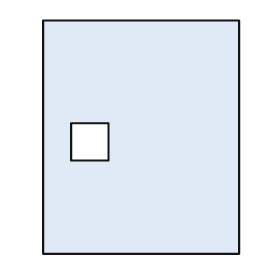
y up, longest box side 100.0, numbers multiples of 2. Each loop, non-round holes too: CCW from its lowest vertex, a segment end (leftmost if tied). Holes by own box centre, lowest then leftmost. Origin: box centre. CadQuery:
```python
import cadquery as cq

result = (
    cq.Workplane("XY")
    .moveTo(-42.0, -50.0)
    .lineTo(42.0, -50.0)
    .lineTo(42.0, 50.0)
    .lineTo(-42.0, 50.0)
    .close()
    .moveTo(-30.0, -10.0)
    .lineTo(-14.0, -10.0)
    .lineTo(-14.0, 6.0)
    .lineTo(-30.0, 6.0)
    .close()
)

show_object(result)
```